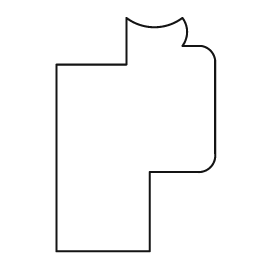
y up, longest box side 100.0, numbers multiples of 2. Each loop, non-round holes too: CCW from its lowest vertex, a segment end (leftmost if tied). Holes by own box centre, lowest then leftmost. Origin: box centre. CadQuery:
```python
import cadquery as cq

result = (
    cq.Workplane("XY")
    .moveTo(-34.0, -50.0)
    .lineTo(6.0, -50.0)
    .lineTo(6.0, -16.0)
    .lineTo(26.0, -16.0)
    .threePointArc((32.0, -14.0), (34.0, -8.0))
    .lineTo(34.0, 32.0)
    .threePointArc((32.0, 36.0), (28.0, 38.0))
    .lineTo(20.0, 38.0)
    .threePointArc((22.0, 44.0), (20.0, 50.0))
    .threePointArc((8.0, 46.0), (-4.0, 50.0))
    .lineTo(-4.0, 30.0)
    .lineTo(-34.0, 30.0)
    .close()
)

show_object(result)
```